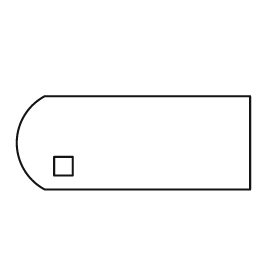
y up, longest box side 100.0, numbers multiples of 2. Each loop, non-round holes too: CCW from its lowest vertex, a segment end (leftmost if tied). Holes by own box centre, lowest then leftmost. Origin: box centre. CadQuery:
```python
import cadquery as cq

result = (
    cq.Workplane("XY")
    .moveTo(-38.0, -20.0)
    .lineTo(50.0, -20.0)
    .lineTo(50.0, 20.0)
    .lineTo(-38.0, 20.0)
    .threePointArc((-50.0, 0.0), (-38.0, -20.0))
    .close()
    .moveTo(-34.0, -14.0)
    .lineTo(-26.0, -14.0)
    .lineTo(-26.0, -6.0)
    .lineTo(-34.0, -6.0)
    .close()
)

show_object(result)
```